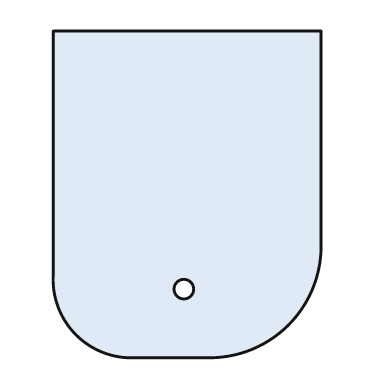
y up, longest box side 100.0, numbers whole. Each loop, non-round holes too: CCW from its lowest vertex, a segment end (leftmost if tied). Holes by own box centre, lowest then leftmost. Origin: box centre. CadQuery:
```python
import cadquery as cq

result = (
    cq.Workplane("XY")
    .moveTo(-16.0, -50.0)
    .lineTo(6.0, -50.0)
    .threePointArc((31.0, -40.0), (41.0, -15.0))
    .lineTo(41.0, 50.0)
    .lineTo(-41.0, 50.0)
    .lineTo(-41.0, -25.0)
    .threePointArc((-34.0, -43.0), (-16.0, -50.0))
    .close()
    .moveTo(-1.0, -29.0)
    .circle(3.0)
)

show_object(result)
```